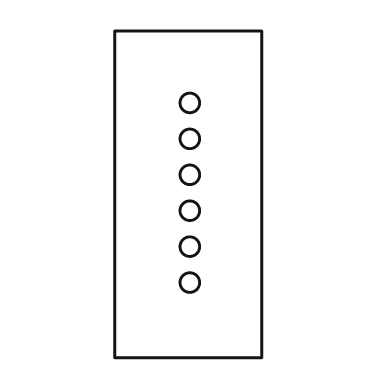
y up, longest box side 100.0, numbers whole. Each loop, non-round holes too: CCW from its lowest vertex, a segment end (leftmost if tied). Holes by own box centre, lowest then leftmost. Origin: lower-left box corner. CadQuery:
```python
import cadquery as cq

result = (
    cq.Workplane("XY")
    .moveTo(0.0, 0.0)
    .lineTo(45.0, 0.0)
    .lineTo(45.0, 100.0)
    .lineTo(0.0, 100.0)
    .close()
    .moveTo(23.0, 23.0)
    .circle(3.0)
    .moveTo(23.0, 34.0)
    .circle(3.0)
    .moveTo(23.0, 45.0)
    .circle(3.0)
    .moveTo(23.0, 56.0)
    .circle(3.0)
    .moveTo(23.0, 67.0)
    .circle(3.0)
    .moveTo(23.0, 78.0)
    .circle(3.0)
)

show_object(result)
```